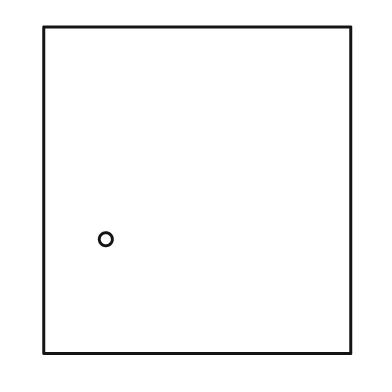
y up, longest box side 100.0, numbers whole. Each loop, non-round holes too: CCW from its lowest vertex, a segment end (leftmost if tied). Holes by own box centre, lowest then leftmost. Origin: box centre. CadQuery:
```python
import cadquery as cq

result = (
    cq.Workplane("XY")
    .moveTo(-47.0, -50.0)
    .lineTo(47.0, -50.0)
    .lineTo(47.0, 50.0)
    .lineTo(-47.0, 50.0)
    .close()
    .moveTo(-28.0, -15.0)
    .circle(2.0)
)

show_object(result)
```